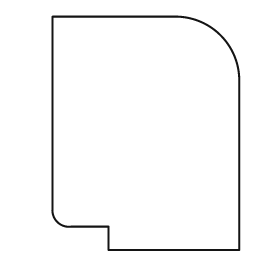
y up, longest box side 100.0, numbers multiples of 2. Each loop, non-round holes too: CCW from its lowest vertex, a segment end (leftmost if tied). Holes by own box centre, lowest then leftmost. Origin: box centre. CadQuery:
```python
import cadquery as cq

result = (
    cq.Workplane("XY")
    .moveTo(-16.0, -50.0)
    .lineTo(40.0, -50.0)
    .lineTo(40.0, 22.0)
    .threePointArc((32.0, 42.0), (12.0, 50.0))
    .lineTo(-40.0, 50.0)
    .lineTo(-40.0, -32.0)
    .threePointArc((-38.0, -38.0), (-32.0, -40.0))
    .lineTo(-16.0, -40.0)
    .close()
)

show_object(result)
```